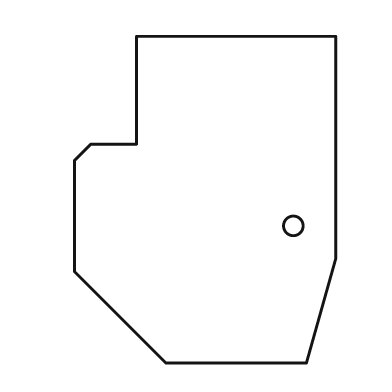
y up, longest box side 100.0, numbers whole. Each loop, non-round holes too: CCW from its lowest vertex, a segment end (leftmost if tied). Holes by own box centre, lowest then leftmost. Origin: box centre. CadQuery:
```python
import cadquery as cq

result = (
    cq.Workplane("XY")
    .moveTo(-12.0, -50.0)
    .lineTo(31.0, -50.0)
    .lineTo(40.0, -18.0)
    .lineTo(40.0, 50.0)
    .lineTo(-21.0, 50.0)
    .lineTo(-21.0, 17.0)
    .lineTo(-35.0, 17.0)
    .lineTo(-40.0, 12.0)
    .lineTo(-40.0, -22.0)
    .close()
    .moveTo(27.0, -8.0)
    .circle(3.0)
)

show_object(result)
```